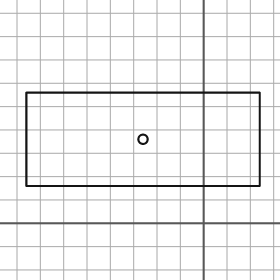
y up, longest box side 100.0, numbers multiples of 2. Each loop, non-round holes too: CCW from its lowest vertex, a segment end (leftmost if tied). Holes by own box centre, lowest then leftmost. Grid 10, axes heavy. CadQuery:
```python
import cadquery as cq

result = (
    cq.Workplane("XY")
    .moveTo(-76.0, 16.0)
    .lineTo(24.0, 16.0)
    .lineTo(24.0, 56.0)
    .lineTo(-76.0, 56.0)
    .close()
    .moveTo(-26.0, 36.0)
    .circle(2.0)
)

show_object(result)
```